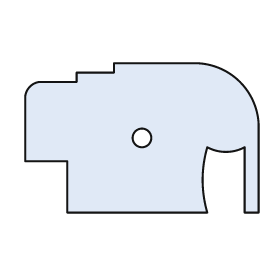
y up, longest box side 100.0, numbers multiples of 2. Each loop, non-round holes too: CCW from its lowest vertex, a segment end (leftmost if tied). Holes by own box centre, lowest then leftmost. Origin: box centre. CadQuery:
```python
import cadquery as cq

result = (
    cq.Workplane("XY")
    .moveTo(-32.0, -32.0)
    .lineTo(28.0, -32.0)
    .threePointArc((26.0, -18.0), (28.0, -4.0))
    .threePointArc((36.0, -6.0), (44.0, -4.0))
    .lineTo(44.0, -32.0)
    .lineTo(50.0, -32.0)
    .lineTo(50.0, 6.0)
    .threePointArc((42.0, 24.0), (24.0, 32.0))
    .lineTo(-12.0, 32.0)
    .lineTo(-12.0, 28.0)
    .lineTo(-28.0, 28.0)
    .lineTo(-28.0, 24.0)
    .lineTo(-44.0, 24.0)
    .threePointArc((-48.0, 22.0), (-50.0, 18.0))
    .lineTo(-50.0, -10.0)
    .lineTo(-32.0, -10.0)
    .close()
    .moveTo(0.0, 0.0)
    .circle(4.0)
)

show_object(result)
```